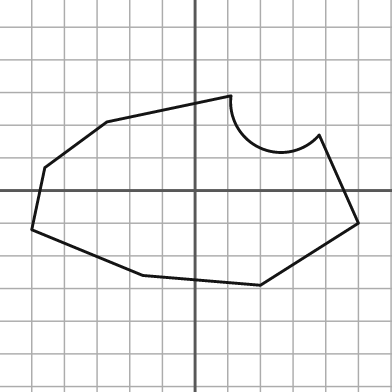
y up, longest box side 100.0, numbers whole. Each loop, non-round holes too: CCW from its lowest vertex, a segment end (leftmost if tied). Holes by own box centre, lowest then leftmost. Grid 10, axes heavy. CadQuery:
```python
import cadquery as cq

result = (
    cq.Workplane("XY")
    .moveTo(20.0, -29.0)
    .lineTo(50.0, -10.0)
    .lineTo(38.0, 17.0)
    .threePointArc((20.0, 13.0), (11.0, 29.0))
    .lineTo(-27.0, 21.0)
    .lineTo(-46.0, 7.0)
    .lineTo(-50.0, -12.0)
    .lineTo(-16.0, -26.0)
    .close()
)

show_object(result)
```